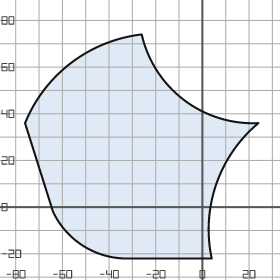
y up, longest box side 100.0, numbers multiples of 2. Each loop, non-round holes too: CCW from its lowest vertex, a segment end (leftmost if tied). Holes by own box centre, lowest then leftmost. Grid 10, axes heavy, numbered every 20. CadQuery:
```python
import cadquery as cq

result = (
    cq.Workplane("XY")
    .moveTo(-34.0, -22.0)
    .lineTo(4.0, -22.0)
    .threePointArc((6.0, 10.0), (24.0, 36.0))
    .threePointArc((-8.0, 46.0), (-26.0, 74.0))
    .threePointArc((-56.0, 62.0), (-76.0, 36.0))
    .lineTo(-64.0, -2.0)
    .threePointArc((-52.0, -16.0), (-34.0, -22.0))
    .close()
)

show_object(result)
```